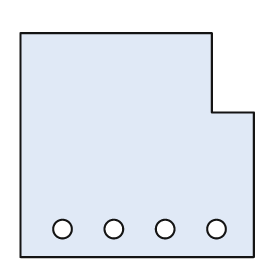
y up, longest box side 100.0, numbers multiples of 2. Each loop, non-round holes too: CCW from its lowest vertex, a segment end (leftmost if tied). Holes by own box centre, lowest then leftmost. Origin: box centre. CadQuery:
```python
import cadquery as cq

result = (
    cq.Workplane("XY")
    .moveTo(-50.0, -48.0)
    .lineTo(50.0, -48.0)
    .lineTo(50.0, 14.0)
    .lineTo(32.0, 14.0)
    .lineTo(32.0, 48.0)
    .lineTo(-50.0, 48.0)
    .close()
    .moveTo(-32.0, -36.0)
    .circle(4.0)
    .moveTo(-10.0, -36.0)
    .circle(4.0)
    .moveTo(12.0, -36.0)
    .circle(4.0)
    .moveTo(34.0, -36.0)
    .circle(4.0)
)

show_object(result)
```